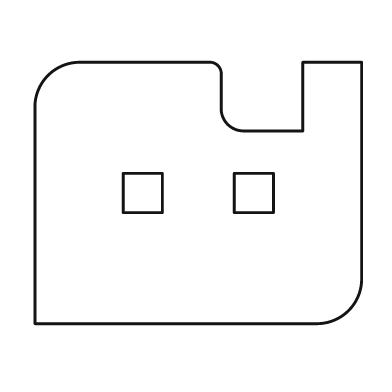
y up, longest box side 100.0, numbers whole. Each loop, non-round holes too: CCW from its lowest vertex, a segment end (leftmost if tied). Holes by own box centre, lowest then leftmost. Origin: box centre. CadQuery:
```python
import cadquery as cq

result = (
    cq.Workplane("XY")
    .moveTo(-50.0, -40.0)
    .lineTo(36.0, -40.0)
    .threePointArc((46.0, -36.0), (50.0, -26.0))
    .lineTo(50.0, 40.0)
    .lineTo(32.0, 40.0)
    .lineTo(32.0, 19.0)
    .lineTo(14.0, 19.0)
    .threePointArc((9.0, 21.0), (7.0, 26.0))
    .lineTo(7.0, 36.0)
    .threePointArc((6.0, 39.0), (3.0, 40.0))
    .lineTo(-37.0, 40.0)
    .threePointArc((-46.0, 36.0), (-50.0, 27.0))
    .close()
    .moveTo(-23.0, -6.0)
    .lineTo(-11.0, -6.0)
    .lineTo(-11.0, 6.0)
    .lineTo(-23.0, 6.0)
    .close()
    .moveTo(11.0, -6.0)
    .lineTo(23.0, -6.0)
    .lineTo(23.0, 6.0)
    .lineTo(11.0, 6.0)
    .close()
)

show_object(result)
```